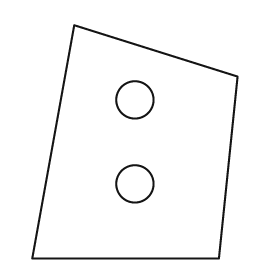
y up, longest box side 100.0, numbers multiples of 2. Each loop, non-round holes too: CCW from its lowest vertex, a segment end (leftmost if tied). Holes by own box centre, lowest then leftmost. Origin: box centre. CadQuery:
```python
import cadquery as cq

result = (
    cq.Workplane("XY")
    .moveTo(-44.0, -50.0)
    .lineTo(36.0, -50.0)
    .lineTo(44.0, 28.0)
    .lineTo(-26.0, 50.0)
    .close()
    .moveTo(0.0, -18.0)
    .circle(8.0)
    .moveTo(0.0, 18.0)
    .circle(8.0)
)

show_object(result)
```